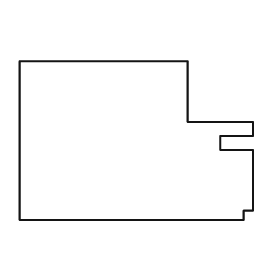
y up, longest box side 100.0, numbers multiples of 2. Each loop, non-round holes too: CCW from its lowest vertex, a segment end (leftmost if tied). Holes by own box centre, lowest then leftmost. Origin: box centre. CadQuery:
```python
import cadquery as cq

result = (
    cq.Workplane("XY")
    .moveTo(-50.0, -34.0)
    .lineTo(46.0, -34.0)
    .lineTo(46.0, -30.0)
    .lineTo(50.0, -30.0)
    .lineTo(50.0, -4.0)
    .lineTo(36.0, -4.0)
    .lineTo(36.0, 2.0)
    .lineTo(50.0, 2.0)
    .lineTo(50.0, 8.0)
    .lineTo(22.0, 8.0)
    .lineTo(22.0, 34.0)
    .lineTo(-50.0, 34.0)
    .close()
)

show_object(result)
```